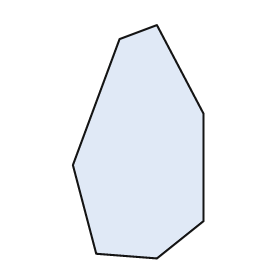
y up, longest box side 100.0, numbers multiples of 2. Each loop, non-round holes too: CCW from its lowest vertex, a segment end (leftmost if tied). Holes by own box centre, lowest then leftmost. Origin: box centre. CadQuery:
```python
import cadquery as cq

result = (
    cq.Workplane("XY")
    .moveTo(8.0, -50.0)
    .lineTo(28.0, -34.0)
    .lineTo(28.0, 12.0)
    .lineTo(8.0, 50.0)
    .lineTo(-8.0, 44.0)
    .lineTo(-28.0, -10.0)
    .lineTo(-18.0, -48.0)
    .close()
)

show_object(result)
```